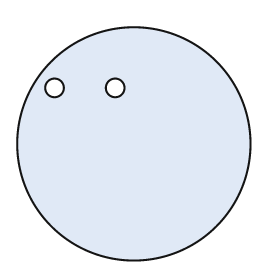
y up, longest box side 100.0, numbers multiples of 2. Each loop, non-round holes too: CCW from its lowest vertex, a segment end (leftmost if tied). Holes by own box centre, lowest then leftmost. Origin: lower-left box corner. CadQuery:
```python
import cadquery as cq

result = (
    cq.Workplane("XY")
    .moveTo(50.0, 50.0)
    .circle(50.0)
    .moveTo(16.0, 74.0)
    .circle(4.0)
    .moveTo(42.0, 74.0)
    .circle(4.0)
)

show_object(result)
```